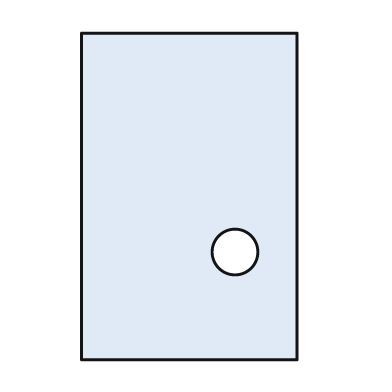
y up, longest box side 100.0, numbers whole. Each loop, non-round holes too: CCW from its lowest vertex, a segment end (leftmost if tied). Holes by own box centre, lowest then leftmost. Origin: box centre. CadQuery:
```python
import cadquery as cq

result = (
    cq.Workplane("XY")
    .moveTo(-33.0, -50.0)
    .lineTo(33.0, -50.0)
    .lineTo(33.0, 50.0)
    .lineTo(-33.0, 50.0)
    .close()
    .moveTo(14.0, -17.0)
    .circle(7.0)
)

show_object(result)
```